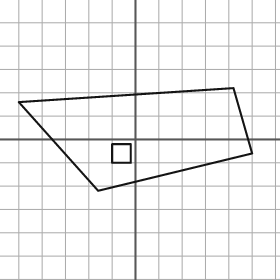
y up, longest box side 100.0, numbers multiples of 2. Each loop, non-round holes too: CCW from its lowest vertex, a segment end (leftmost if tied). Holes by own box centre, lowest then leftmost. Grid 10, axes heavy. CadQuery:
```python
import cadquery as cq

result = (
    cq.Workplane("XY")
    .moveTo(-16.0, -22.0)
    .lineTo(50.0, -6.0)
    .lineTo(42.0, 22.0)
    .lineTo(-50.0, 16.0)
    .close()
    .moveTo(-10.0, -10.0)
    .lineTo(-2.0, -10.0)
    .lineTo(-2.0, -2.0)
    .lineTo(-10.0, -2.0)
    .close()
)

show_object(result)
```